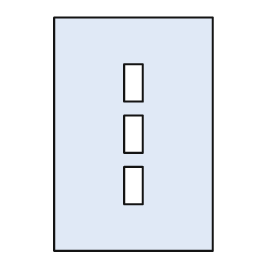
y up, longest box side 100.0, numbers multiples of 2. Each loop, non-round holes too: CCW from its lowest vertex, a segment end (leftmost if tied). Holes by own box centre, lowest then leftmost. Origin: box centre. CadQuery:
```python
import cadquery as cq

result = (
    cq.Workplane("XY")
    .moveTo(-34.0, -50.0)
    .lineTo(34.0, -50.0)
    .lineTo(34.0, 50.0)
    .lineTo(-34.0, 50.0)
    .close()
    .moveTo(-4.0, -30.0)
    .lineTo(4.0, -30.0)
    .lineTo(4.0, -14.0)
    .lineTo(-4.0, -14.0)
    .close()
    .moveTo(-4.0, -8.0)
    .lineTo(4.0, -8.0)
    .lineTo(4.0, 8.0)
    .lineTo(-4.0, 8.0)
    .close()
    .moveTo(-4.0, 14.0)
    .lineTo(4.0, 14.0)
    .lineTo(4.0, 30.0)
    .lineTo(-4.0, 30.0)
    .close()
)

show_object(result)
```